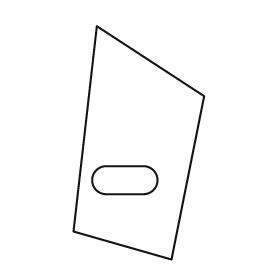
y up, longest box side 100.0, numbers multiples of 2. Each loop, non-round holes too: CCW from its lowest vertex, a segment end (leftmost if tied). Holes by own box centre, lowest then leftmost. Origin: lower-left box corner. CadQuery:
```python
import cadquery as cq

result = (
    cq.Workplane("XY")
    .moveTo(42.0, 0.0)
    .lineTo(56.0, 70.0)
    .lineTo(10.0, 100.0)
    .lineTo(0.0, 12.0)
    .close()
    .moveTo(14.0, 28.0)
    .lineTo(30.0, 28.0)
    .threePointArc((36.0, 34.0), (30.0, 40.0))
    .lineTo(14.0, 40.0)
    .threePointArc((8.0, 34.0), (14.0, 28.0))
    .close()
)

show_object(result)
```